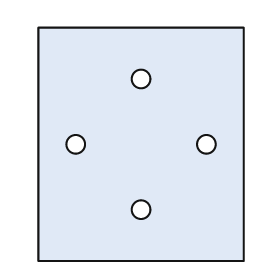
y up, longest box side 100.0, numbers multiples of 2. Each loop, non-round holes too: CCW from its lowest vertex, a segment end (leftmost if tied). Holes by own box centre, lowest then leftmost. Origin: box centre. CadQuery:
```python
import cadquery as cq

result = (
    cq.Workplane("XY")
    .moveTo(-44.0, -50.0)
    .lineTo(44.0, -50.0)
    .lineTo(44.0, 50.0)
    .lineTo(-44.0, 50.0)
    .close()
    .moveTo(0.0, -28.0)
    .circle(4.0)
    .moveTo(-28.0, 0.0)
    .circle(4.0)
    .moveTo(28.0, 0.0)
    .circle(4.0)
    .moveTo(0.0, 28.0)
    .circle(4.0)
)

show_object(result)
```